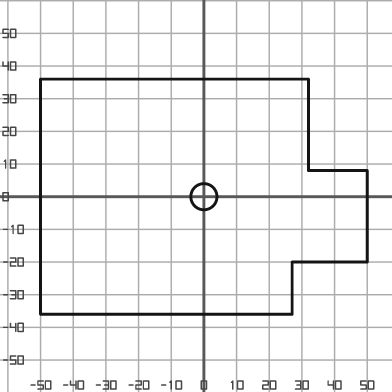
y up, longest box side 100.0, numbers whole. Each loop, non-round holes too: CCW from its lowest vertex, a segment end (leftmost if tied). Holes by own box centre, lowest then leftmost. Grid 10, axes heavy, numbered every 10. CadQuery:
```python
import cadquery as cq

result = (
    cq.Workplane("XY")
    .moveTo(-50.0, -36.0)
    .lineTo(27.0, -36.0)
    .lineTo(27.0, -20.0)
    .lineTo(50.0, -20.0)
    .lineTo(50.0, 8.0)
    .lineTo(32.0, 8.0)
    .lineTo(32.0, 36.0)
    .lineTo(-50.0, 36.0)
    .close()
    .moveTo(0.0, 0.0)
    .circle(4.0)
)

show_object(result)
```